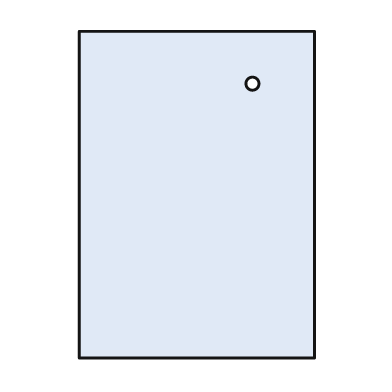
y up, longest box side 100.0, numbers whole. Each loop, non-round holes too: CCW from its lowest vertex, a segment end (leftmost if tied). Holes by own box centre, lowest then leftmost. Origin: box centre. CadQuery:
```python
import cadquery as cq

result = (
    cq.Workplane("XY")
    .moveTo(-36.0, -50.0)
    .lineTo(36.0, -50.0)
    .lineTo(36.0, 50.0)
    .lineTo(-36.0, 50.0)
    .close()
    .moveTo(17.0, 34.0)
    .circle(2.0)
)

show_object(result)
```